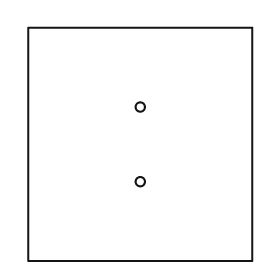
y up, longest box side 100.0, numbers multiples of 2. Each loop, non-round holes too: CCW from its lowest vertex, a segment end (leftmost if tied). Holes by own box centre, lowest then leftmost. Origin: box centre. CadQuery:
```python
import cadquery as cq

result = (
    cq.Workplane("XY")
    .moveTo(-48.0, -50.0)
    .lineTo(48.0, -50.0)
    .lineTo(48.0, 50.0)
    .lineTo(-48.0, 50.0)
    .close()
    .moveTo(0.0, -16.0)
    .circle(2.0)
    .moveTo(0.0, 16.0)
    .circle(2.0)
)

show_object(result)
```